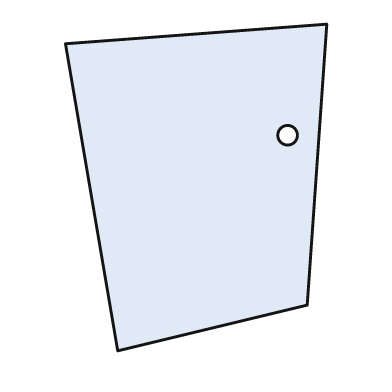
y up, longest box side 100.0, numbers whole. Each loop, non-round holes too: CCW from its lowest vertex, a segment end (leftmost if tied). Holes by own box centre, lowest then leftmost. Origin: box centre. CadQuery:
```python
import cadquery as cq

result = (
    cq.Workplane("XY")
    .moveTo(-24.0, -50.0)
    .lineTo(34.0, -36.0)
    .lineTo(40.0, 50.0)
    .lineTo(-40.0, 44.0)
    .close()
    .moveTo(28.0, 16.0)
    .circle(3.0)
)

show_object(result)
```